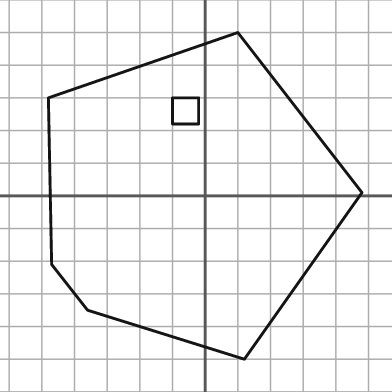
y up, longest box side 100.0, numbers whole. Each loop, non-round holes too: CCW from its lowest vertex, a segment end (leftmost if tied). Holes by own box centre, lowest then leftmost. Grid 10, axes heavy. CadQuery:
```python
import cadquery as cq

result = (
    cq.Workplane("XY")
    .moveTo(12.0, -50.0)
    .lineTo(48.0, 1.0)
    .lineTo(10.0, 50.0)
    .lineTo(-48.0, 30.0)
    .lineTo(-47.0, -21.0)
    .lineTo(-36.0, -35.0)
    .close()
    .moveTo(-10.0, 22.0)
    .lineTo(-2.0, 22.0)
    .lineTo(-2.0, 30.0)
    .lineTo(-10.0, 30.0)
    .close()
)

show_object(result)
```